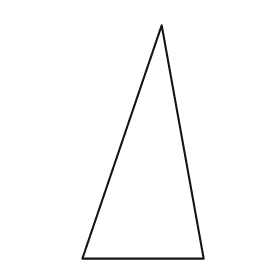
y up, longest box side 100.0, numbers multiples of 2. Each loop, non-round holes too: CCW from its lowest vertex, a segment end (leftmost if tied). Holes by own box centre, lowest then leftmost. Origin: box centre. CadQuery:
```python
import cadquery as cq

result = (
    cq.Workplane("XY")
    .moveTo(-26.0, -50.0)
    .lineTo(26.0, -50.0)
    .lineTo(8.0, 50.0)
    .close()
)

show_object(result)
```